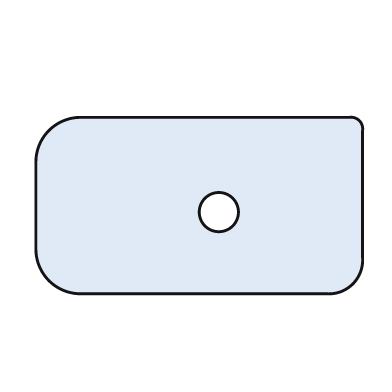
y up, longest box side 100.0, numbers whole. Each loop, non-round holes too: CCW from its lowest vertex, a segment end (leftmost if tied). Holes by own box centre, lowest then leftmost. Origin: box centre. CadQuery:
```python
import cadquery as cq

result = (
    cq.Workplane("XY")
    .moveTo(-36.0, -27.0)
    .lineTo(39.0, -27.0)
    .threePointArc((47.0, -24.0), (50.0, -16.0))
    .lineTo(50.0, 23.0)
    .threePointArc((49.0, 26.0), (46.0, 27.0))
    .lineTo(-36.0, 27.0)
    .threePointArc((-46.0, 23.0), (-50.0, 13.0))
    .lineTo(-50.0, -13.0)
    .threePointArc((-46.0, -23.0), (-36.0, -27.0))
    .close()
    .moveTo(6.0, -2.0)
    .circle(6.0)
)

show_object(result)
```